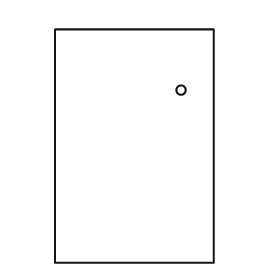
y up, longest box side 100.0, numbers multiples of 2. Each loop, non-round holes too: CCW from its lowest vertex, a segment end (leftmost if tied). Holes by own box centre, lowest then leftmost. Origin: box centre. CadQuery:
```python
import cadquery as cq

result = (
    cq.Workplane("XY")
    .moveTo(-34.0, -50.0)
    .lineTo(34.0, -50.0)
    .lineTo(34.0, 50.0)
    .lineTo(-34.0, 50.0)
    .close()
    .moveTo(20.0, 24.0)
    .circle(2.0)
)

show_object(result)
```